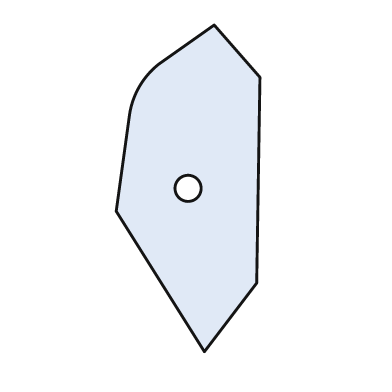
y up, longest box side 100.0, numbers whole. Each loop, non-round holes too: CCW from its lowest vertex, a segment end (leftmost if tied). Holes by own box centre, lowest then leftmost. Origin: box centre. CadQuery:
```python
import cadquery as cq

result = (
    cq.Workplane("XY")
    .moveTo(5.0, -50.0)
    .lineTo(21.0, -29.0)
    .lineTo(22.0, 34.0)
    .lineTo(8.0, 50.0)
    .lineTo(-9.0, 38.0)
    .threePointArc((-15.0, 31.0), (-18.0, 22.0))
    .lineTo(-22.0, -7.0)
    .close()
    .moveTo(0.0, 0.0)
    .circle(4.0)
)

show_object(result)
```